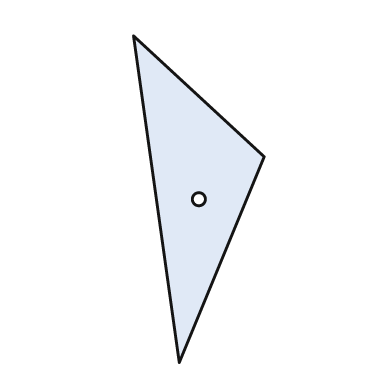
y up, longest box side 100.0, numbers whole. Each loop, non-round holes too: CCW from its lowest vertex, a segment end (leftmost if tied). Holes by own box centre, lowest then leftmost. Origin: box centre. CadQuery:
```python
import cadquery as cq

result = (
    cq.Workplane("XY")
    .moveTo(-6.0, -50.0)
    .lineTo(20.0, 13.0)
    .lineTo(-20.0, 50.0)
    .close()
    .moveTo(0.0, 0.0)
    .circle(2.0)
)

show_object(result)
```